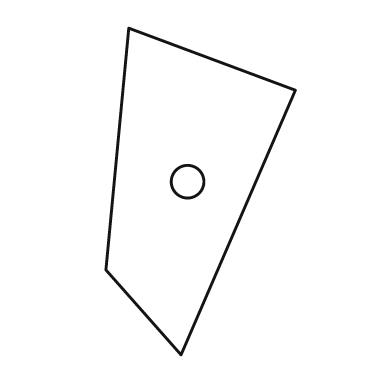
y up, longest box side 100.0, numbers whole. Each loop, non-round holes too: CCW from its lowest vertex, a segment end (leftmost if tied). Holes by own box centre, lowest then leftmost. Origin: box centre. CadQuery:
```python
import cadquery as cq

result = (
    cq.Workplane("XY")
    .moveTo(-6.0, -50.0)
    .lineTo(29.0, 31.0)
    .lineTo(-22.0, 50.0)
    .lineTo(-29.0, -24.0)
    .close()
    .moveTo(-4.0, 3.0)
    .circle(5.0)
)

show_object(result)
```